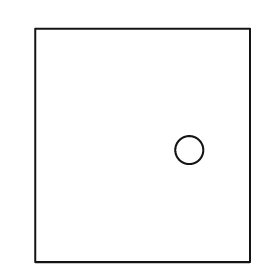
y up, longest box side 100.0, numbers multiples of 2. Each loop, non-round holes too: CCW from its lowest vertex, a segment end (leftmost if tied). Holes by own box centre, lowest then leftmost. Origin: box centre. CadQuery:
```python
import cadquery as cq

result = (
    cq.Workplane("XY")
    .moveTo(-46.0, -50.0)
    .lineTo(46.0, -50.0)
    .lineTo(46.0, 50.0)
    .lineTo(-46.0, 50.0)
    .close()
    .moveTo(20.0, -2.0)
    .circle(6.0)
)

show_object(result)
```